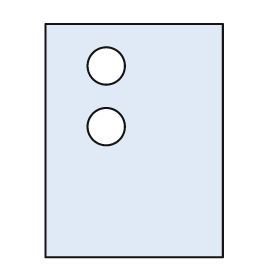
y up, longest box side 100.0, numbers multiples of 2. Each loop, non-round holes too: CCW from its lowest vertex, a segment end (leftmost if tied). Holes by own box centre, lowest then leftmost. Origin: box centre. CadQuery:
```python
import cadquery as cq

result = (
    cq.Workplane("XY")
    .moveTo(-38.0, -50.0)
    .lineTo(38.0, -50.0)
    .lineTo(38.0, 50.0)
    .lineTo(-38.0, 50.0)
    .close()
    .moveTo(-12.0, 6.0)
    .circle(8.0)
    .moveTo(-12.0, 32.0)
    .circle(8.0)
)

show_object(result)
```